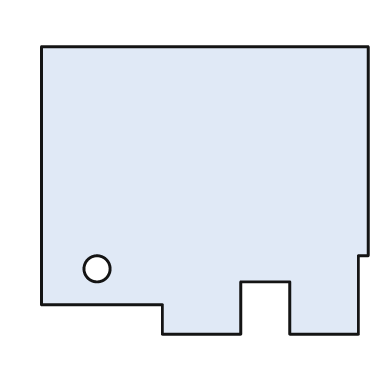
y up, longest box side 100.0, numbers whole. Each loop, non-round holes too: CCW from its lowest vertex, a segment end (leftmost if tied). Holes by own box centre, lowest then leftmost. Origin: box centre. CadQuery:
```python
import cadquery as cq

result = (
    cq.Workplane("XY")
    .moveTo(-13.0, -44.0)
    .lineTo(11.0, -44.0)
    .lineTo(11.0, -28.0)
    .lineTo(26.0, -28.0)
    .lineTo(26.0, -44.0)
    .lineTo(47.0, -44.0)
    .lineTo(47.0, -20.0)
    .lineTo(50.0, -20.0)
    .lineTo(50.0, 44.0)
    .lineTo(-50.0, 44.0)
    .lineTo(-50.0, -35.0)
    .lineTo(-13.0, -35.0)
    .close()
    .moveTo(-33.0, -24.0)
    .circle(4.0)
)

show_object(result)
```